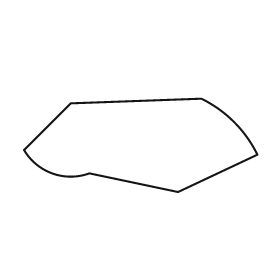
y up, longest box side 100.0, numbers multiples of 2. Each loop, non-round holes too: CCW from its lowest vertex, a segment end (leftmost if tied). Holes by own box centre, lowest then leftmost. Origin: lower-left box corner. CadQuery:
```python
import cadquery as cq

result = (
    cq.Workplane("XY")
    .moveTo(66.0, 0.0)
    .lineTo(100.0, 16.0)
    .threePointArc((90.0, 30.0), (76.0, 40.0))
    .lineTo(20.0, 38.0)
    .lineTo(0.0, 18.0)
    .threePointArc((12.0, 8.0), (28.0, 8.0))
    .close()
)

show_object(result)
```